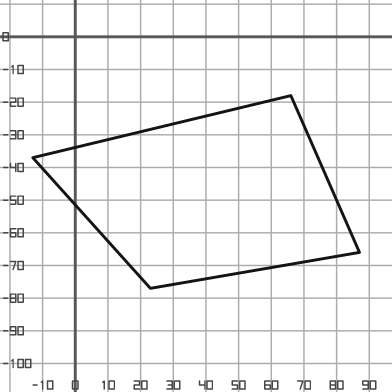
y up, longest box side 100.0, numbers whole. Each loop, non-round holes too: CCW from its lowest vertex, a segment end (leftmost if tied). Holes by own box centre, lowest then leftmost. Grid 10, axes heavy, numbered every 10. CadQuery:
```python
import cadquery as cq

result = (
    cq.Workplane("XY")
    .moveTo(23.0, -77.0)
    .lineTo(87.0, -66.0)
    .lineTo(66.0, -18.0)
    .lineTo(-13.0, -37.0)
    .close()
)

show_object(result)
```